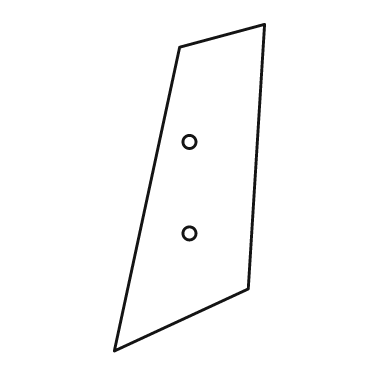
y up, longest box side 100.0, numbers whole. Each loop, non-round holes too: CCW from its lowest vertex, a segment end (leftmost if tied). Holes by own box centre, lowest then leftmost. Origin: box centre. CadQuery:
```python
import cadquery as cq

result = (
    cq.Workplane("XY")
    .moveTo(-23.0, -50.0)
    .lineTo(18.0, -31.0)
    .lineTo(23.0, 50.0)
    .lineTo(-3.0, 43.0)
    .close()
    .moveTo(0.0, -14.0)
    .circle(2.0)
    .moveTo(0.0, 14.0)
    .circle(2.0)
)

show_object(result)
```